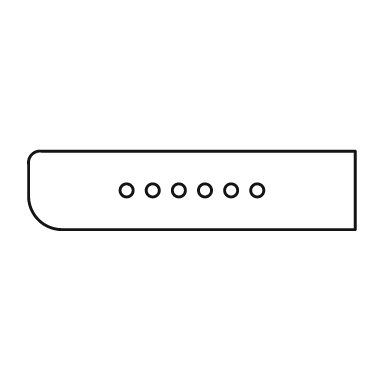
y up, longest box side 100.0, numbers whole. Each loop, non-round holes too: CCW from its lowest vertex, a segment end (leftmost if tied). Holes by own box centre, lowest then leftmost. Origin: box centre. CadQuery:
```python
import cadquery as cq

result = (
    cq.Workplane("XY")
    .moveTo(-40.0, -12.0)
    .lineTo(50.0, -12.0)
    .lineTo(50.0, 12.0)
    .lineTo(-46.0, 12.0)
    .threePointArc((-49.0, 11.0), (-50.0, 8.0))
    .lineTo(-50.0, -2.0)
    .threePointArc((-47.0, -9.0), (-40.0, -12.0))
    .close()
    .moveTo(-20.0, 0.0)
    .circle(2.0)
    .moveTo(-12.0, 0.0)
    .circle(2.0)
    .moveTo(-4.0, 0.0)
    .circle(2.0)
    .moveTo(4.0, 0.0)
    .circle(2.0)
    .moveTo(12.0, 0.0)
    .circle(2.0)
    .moveTo(20.0, 0.0)
    .circle(2.0)
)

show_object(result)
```